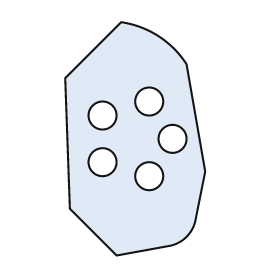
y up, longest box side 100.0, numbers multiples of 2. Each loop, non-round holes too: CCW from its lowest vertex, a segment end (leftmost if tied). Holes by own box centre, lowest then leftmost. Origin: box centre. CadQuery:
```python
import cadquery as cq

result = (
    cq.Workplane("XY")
    .moveTo(-8.0, -50.0)
    .lineTo(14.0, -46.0)
    .threePointArc((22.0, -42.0), (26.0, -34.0))
    .lineTo(30.0, -14.0)
    .lineTo(22.0, 32.0)
    .threePointArc((10.0, 44.0), (-6.0, 50.0))
    .lineTo(-30.0, 26.0)
    .lineTo(-28.0, -30.0)
    .close()
    .moveTo(6.0, -16.0)
    .circle(6.0)
    .moveTo(-14.0, -10.0)
    .circle(6.0)
    .moveTo(16.0, 0.0)
    .circle(6.0)
    .moveTo(-14.0, 10.0)
    .circle(6.0)
    .moveTo(6.0, 16.0)
    .circle(6.0)
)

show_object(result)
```